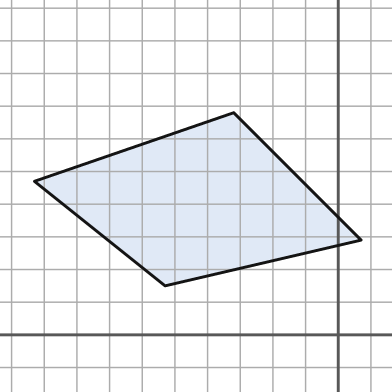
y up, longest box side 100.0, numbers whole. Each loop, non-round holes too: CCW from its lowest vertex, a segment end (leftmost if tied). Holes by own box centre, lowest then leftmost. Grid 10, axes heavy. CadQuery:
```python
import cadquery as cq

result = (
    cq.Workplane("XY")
    .moveTo(-53.0, 15.0)
    .lineTo(7.0, 29.0)
    .lineTo(-32.0, 68.0)
    .lineTo(-93.0, 47.0)
    .close()
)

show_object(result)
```